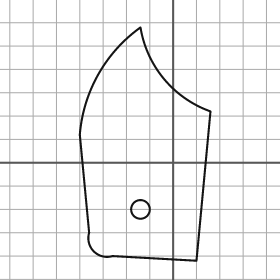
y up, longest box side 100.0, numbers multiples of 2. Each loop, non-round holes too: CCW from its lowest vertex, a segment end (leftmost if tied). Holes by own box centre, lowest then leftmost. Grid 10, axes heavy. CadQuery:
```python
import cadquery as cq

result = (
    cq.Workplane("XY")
    .moveTo(10.0, -42.0)
    .lineTo(16.0, 22.0)
    .threePointArc((-4.0, 36.0), (-14.0, 58.0))
    .threePointArc((-32.0, 38.0), (-40.0, 12.0))
    .lineTo(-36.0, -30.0)
    .threePointArc((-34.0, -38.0), (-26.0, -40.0))
    .close()
    .moveTo(-14.0, -20.0)
    .circle(4.0)
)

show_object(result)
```